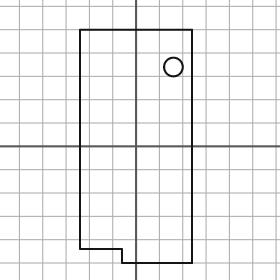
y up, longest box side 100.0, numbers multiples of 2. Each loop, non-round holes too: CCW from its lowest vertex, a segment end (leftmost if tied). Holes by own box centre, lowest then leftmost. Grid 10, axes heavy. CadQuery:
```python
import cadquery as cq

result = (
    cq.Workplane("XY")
    .moveTo(-6.0, -50.0)
    .lineTo(24.0, -50.0)
    .lineTo(24.0, 50.0)
    .lineTo(-24.0, 50.0)
    .lineTo(-24.0, -44.0)
    .lineTo(-6.0, -44.0)
    .close()
    .moveTo(16.0, 34.0)
    .circle(4.0)
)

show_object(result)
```